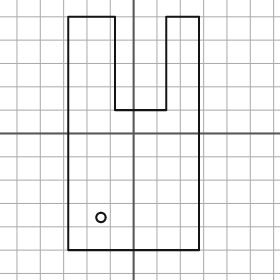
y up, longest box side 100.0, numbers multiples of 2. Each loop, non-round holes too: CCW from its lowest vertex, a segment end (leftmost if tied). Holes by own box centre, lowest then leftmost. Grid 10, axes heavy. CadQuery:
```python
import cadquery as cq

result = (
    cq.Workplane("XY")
    .moveTo(-28.0, -50.0)
    .lineTo(28.0, -50.0)
    .lineTo(28.0, 50.0)
    .lineTo(14.0, 50.0)
    .lineTo(14.0, 10.0)
    .lineTo(-8.0, 10.0)
    .lineTo(-8.0, 50.0)
    .lineTo(-28.0, 50.0)
    .close()
    .moveTo(-14.0, -36.0)
    .circle(2.0)
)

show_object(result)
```